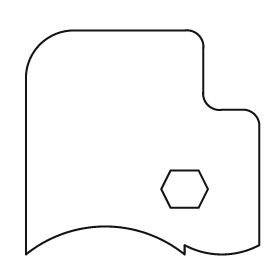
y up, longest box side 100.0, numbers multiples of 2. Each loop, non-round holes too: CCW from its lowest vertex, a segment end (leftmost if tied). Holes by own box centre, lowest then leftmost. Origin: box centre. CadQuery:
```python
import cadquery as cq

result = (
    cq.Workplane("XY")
    .moveTo(-50.0, -48.0)
    .threePointArc((-16.0, -36.0), (18.0, -48.0))
    .lineTo(18.0, -44.0)
    .threePointArc((34.0, -48.0), (50.0, -44.0))
    .lineTo(50.0, 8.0)
    .threePointArc((48.0, 12.0), (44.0, 14.0))
    .lineTo(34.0, 14.0)
    .threePointArc((28.0, 16.0), (26.0, 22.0))
    .lineTo(26.0, 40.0)
    .threePointArc((24.0, 46.0), (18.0, 48.0))
    .lineTo(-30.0, 48.0)
    .threePointArc((-44.0, 42.0), (-50.0, 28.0))
    .close()
    .moveTo(12.0, -28.0)
    .lineTo(24.0, -28.0)
    .lineTo(28.0, -20.0)
    .lineTo(24.0, -12.0)
    .lineTo(12.0, -12.0)
    .lineTo(8.0, -20.0)
    .close()
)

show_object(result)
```